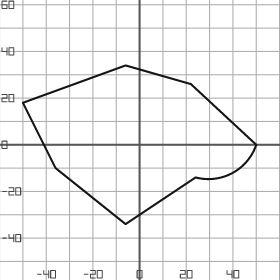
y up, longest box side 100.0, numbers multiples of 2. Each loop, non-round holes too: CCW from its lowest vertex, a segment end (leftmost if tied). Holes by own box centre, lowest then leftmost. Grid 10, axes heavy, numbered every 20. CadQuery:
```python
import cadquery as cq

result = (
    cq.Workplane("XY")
    .moveTo(-6.0, -34.0)
    .lineTo(24.0, -14.0)
    .threePointArc((40.0, -12.0), (50.0, 0.0))
    .lineTo(22.0, 26.0)
    .lineTo(-6.0, 34.0)
    .lineTo(-50.0, 18.0)
    .lineTo(-36.0, -10.0)
    .close()
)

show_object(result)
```